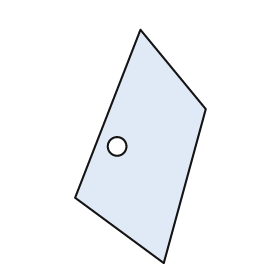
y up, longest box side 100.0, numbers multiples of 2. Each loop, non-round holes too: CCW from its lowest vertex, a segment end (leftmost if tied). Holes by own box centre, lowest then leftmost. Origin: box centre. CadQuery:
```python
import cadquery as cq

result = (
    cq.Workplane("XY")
    .moveTo(10.0, -50.0)
    .lineTo(28.0, 16.0)
    .lineTo(0.0, 50.0)
    .lineTo(-28.0, -22.0)
    .close()
    .moveTo(-10.0, 0.0)
    .circle(4.0)
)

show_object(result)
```